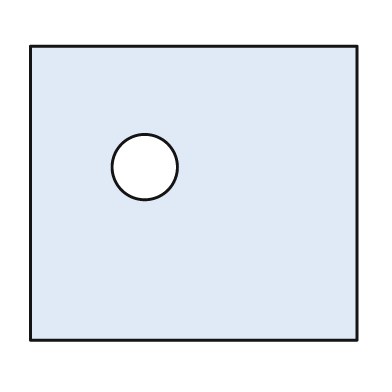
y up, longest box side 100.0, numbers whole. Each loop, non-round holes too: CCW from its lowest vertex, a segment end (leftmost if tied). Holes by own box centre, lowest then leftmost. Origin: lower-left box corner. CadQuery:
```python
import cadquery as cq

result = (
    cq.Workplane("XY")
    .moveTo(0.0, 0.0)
    .lineTo(100.0, 0.0)
    .lineTo(100.0, 90.0)
    .lineTo(0.0, 90.0)
    .close()
    .moveTo(35.0, 53.0)
    .circle(10.0)
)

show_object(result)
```